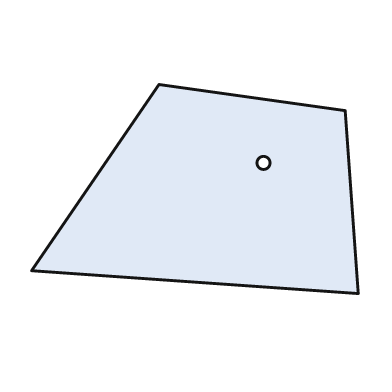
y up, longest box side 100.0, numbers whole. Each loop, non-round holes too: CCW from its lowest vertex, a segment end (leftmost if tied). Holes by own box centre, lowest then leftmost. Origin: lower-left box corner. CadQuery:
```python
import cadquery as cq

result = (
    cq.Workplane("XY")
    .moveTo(100.0, 0.0)
    .lineTo(96.0, 56.0)
    .lineTo(39.0, 64.0)
    .lineTo(0.0, 7.0)
    .close()
    .moveTo(71.0, 40.0)
    .circle(2.0)
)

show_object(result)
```